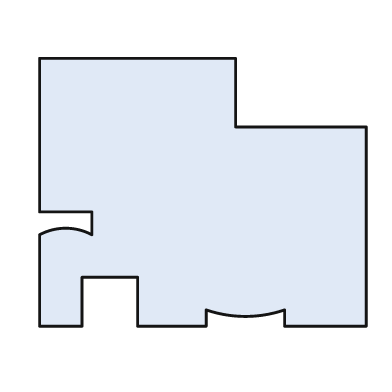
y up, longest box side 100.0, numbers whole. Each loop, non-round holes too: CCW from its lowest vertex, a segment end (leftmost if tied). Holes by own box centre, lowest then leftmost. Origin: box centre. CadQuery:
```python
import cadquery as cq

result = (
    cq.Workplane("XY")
    .moveTo(-50.0, -41.0)
    .lineTo(-37.0, -41.0)
    .lineTo(-37.0, -26.0)
    .lineTo(-20.0, -26.0)
    .lineTo(-20.0, -41.0)
    .lineTo(1.0, -41.0)
    .lineTo(1.0, -36.0)
    .threePointArc((13.0, -38.0), (25.0, -36.0))
    .lineTo(25.0, -41.0)
    .lineTo(50.0, -41.0)
    .lineTo(50.0, 20.0)
    .lineTo(10.0, 20.0)
    .lineTo(10.0, 41.0)
    .lineTo(-50.0, 41.0)
    .lineTo(-50.0, -6.0)
    .lineTo(-34.0, -6.0)
    .lineTo(-34.0, -13.0)
    .threePointArc((-42.0, -11.0), (-50.0, -13.0))
    .close()
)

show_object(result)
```